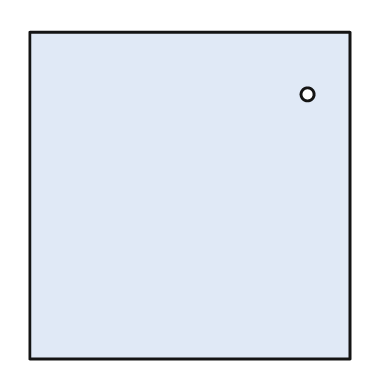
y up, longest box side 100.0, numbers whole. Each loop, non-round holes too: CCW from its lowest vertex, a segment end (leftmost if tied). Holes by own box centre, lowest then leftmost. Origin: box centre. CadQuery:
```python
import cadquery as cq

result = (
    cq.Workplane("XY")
    .moveTo(-49.0, -50.0)
    .lineTo(49.0, -50.0)
    .lineTo(49.0, 50.0)
    .lineTo(-49.0, 50.0)
    .close()
    .moveTo(36.0, 31.0)
    .circle(2.0)
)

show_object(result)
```